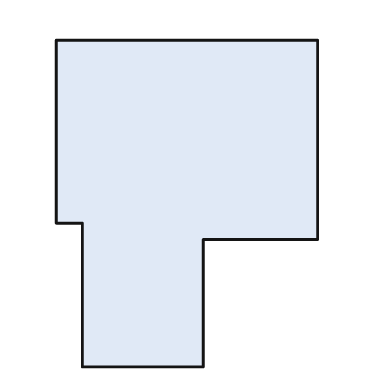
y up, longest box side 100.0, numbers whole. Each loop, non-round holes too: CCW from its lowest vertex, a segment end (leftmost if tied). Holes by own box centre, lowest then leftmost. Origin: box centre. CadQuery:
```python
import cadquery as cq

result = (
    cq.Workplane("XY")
    .moveTo(-32.0, -50.0)
    .lineTo(5.0, -50.0)
    .lineTo(5.0, -11.0)
    .lineTo(40.0, -11.0)
    .lineTo(40.0, 50.0)
    .lineTo(-40.0, 50.0)
    .lineTo(-40.0, -6.0)
    .lineTo(-32.0, -6.0)
    .close()
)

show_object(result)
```